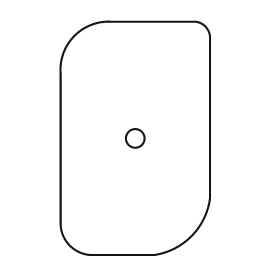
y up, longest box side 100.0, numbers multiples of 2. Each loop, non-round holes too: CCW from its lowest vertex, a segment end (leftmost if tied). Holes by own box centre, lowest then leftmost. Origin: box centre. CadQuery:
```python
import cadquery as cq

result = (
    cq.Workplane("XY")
    .moveTo(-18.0, -50.0)
    .lineTo(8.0, -50.0)
    .threePointArc((24.0, -42.0), (32.0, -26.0))
    .lineTo(32.0, 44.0)
    .threePointArc((30.0, 48.0), (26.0, 50.0))
    .lineTo(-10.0, 50.0)
    .threePointArc((-26.0, 44.0), (-32.0, 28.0))
    .lineTo(-32.0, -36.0)
    .threePointArc((-28.0, -46.0), (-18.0, -50.0))
    .close()
    .moveTo(0.0, 0.0)
    .circle(4.0)
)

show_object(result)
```